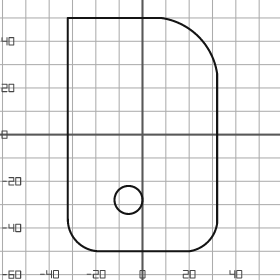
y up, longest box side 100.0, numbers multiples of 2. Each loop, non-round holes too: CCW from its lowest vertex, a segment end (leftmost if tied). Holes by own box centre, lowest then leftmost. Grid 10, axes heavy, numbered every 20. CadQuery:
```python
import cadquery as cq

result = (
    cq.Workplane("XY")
    .moveTo(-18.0, -50.0)
    .lineTo(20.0, -50.0)
    .threePointArc((28.0, -46.0), (32.0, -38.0))
    .lineTo(32.0, 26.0)
    .threePointArc((24.0, 42.0), (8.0, 50.0))
    .lineTo(-32.0, 50.0)
    .lineTo(-32.0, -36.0)
    .threePointArc((-28.0, -46.0), (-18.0, -50.0))
    .close()
    .moveTo(-6.0, -28.0)
    .circle(6.0)
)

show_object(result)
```